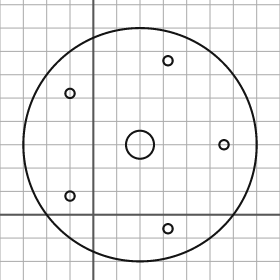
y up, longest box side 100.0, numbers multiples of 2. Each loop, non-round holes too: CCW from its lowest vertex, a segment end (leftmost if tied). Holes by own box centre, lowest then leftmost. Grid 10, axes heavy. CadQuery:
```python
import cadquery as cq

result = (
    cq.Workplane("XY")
    .moveTo(20.0, 30.0)
    .circle(50.0)
    .moveTo(32.0, -6.0)
    .circle(2.0)
    .moveTo(-10.0, 8.0)
    .circle(2.0)
    .moveTo(20.0, 30.0)
    .circle(6.0)
    .moveTo(56.0, 30.0)
    .circle(2.0)
    .moveTo(-10.0, 52.0)
    .circle(2.0)
    .moveTo(32.0, 66.0)
    .circle(2.0)
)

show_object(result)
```